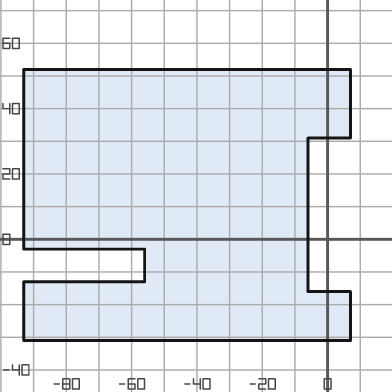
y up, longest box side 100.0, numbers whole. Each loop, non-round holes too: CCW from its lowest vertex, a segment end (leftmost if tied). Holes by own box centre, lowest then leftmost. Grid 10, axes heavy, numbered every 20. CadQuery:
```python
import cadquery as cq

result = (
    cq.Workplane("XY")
    .moveTo(-93.0, -31.0)
    .lineTo(7.0, -31.0)
    .lineTo(7.0, -16.0)
    .lineTo(-6.0, -16.0)
    .lineTo(-6.0, 31.0)
    .lineTo(7.0, 31.0)
    .lineTo(7.0, 52.0)
    .lineTo(-93.0, 52.0)
    .lineTo(-93.0, -3.0)
    .lineTo(-56.0, -3.0)
    .lineTo(-56.0, -13.0)
    .lineTo(-93.0, -13.0)
    .close()
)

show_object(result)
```